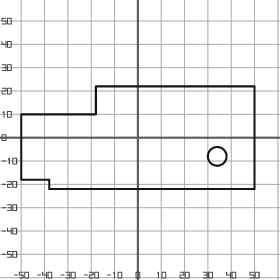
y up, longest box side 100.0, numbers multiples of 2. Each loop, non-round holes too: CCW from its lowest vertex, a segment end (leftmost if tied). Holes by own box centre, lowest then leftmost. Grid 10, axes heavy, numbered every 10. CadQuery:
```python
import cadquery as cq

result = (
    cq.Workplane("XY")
    .moveTo(-38.0, -22.0)
    .lineTo(50.0, -22.0)
    .lineTo(50.0, 22.0)
    .lineTo(-18.0, 22.0)
    .lineTo(-18.0, 10.0)
    .lineTo(-50.0, 10.0)
    .lineTo(-50.0, -18.0)
    .lineTo(-38.0, -18.0)
    .close()
    .moveTo(34.0, -8.0)
    .circle(4.0)
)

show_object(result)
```